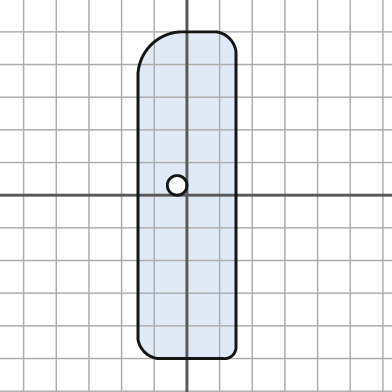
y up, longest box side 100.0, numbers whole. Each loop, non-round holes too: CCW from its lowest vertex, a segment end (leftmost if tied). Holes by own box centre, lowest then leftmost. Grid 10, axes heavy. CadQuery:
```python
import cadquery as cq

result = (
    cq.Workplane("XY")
    .moveTo(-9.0, -50.0)
    .lineTo(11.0, -50.0)
    .threePointArc((14.0, -49.0), (15.0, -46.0))
    .lineTo(15.0, 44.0)
    .threePointArc((13.0, 48.0), (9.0, 50.0))
    .lineTo(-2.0, 50.0)
    .threePointArc((-11.0, 46.0), (-15.0, 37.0))
    .lineTo(-15.0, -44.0)
    .threePointArc((-13.0, -48.0), (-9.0, -50.0))
    .close()
    .moveTo(-3.0, 3.0)
    .circle(3.0)
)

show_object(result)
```